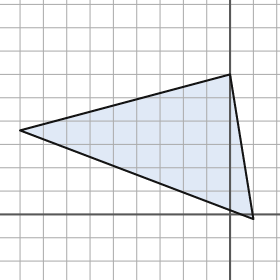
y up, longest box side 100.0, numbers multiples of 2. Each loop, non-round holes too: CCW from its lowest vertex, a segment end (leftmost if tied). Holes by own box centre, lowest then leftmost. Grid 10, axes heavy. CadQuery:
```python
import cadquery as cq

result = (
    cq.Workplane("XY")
    .moveTo(10.0, -2.0)
    .lineTo(0.0, 60.0)
    .lineTo(-90.0, 36.0)
    .close()
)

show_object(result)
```